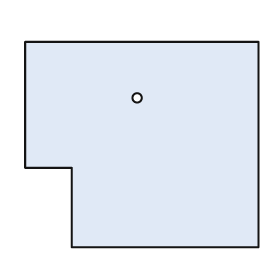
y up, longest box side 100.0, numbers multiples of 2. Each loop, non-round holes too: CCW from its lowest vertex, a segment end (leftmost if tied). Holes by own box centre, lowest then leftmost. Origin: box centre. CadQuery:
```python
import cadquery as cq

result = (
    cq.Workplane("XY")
    .moveTo(-30.0, -44.0)
    .lineTo(50.0, -44.0)
    .lineTo(50.0, 44.0)
    .lineTo(-50.0, 44.0)
    .lineTo(-50.0, -10.0)
    .lineTo(-30.0, -10.0)
    .close()
    .moveTo(-2.0, 20.0)
    .circle(2.0)
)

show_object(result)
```